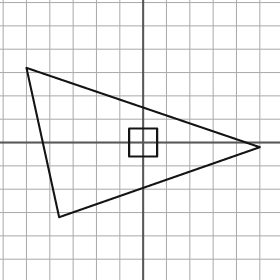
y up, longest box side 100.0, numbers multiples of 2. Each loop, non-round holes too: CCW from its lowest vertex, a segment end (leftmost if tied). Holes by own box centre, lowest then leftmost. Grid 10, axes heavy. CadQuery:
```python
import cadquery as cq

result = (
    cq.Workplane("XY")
    .moveTo(-36.0, -32.0)
    .lineTo(50.0, -2.0)
    .lineTo(-50.0, 32.0)
    .close()
    .moveTo(-6.0, -6.0)
    .lineTo(6.0, -6.0)
    .lineTo(6.0, 6.0)
    .lineTo(-6.0, 6.0)
    .close()
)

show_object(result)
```